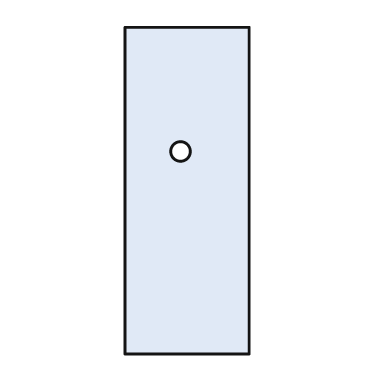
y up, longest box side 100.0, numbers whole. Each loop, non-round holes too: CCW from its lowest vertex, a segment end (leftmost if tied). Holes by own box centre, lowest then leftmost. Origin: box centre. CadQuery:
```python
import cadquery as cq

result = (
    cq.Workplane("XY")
    .moveTo(-19.0, -50.0)
    .lineTo(19.0, -50.0)
    .lineTo(19.0, 50.0)
    .lineTo(-19.0, 50.0)
    .close()
    .moveTo(-2.0, 12.0)
    .circle(3.0)
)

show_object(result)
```